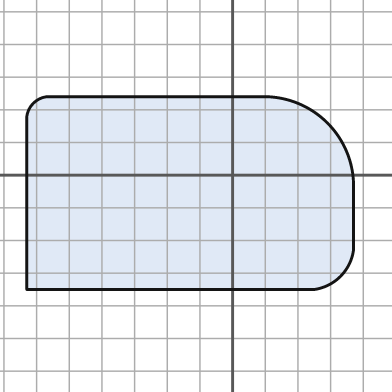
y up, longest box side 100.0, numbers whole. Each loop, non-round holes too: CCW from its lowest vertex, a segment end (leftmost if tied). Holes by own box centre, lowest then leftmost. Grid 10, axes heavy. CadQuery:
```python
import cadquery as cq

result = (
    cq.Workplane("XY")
    .moveTo(-63.0, -35.0)
    .lineTo(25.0, -35.0)
    .threePointArc((33.0, -31.0), (37.0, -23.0))
    .lineTo(37.0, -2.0)
    .threePointArc((29.0, 16.0), (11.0, 24.0))
    .lineTo(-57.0, 24.0)
    .threePointArc((-61.0, 22.0), (-63.0, 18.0))
    .close()
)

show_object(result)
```